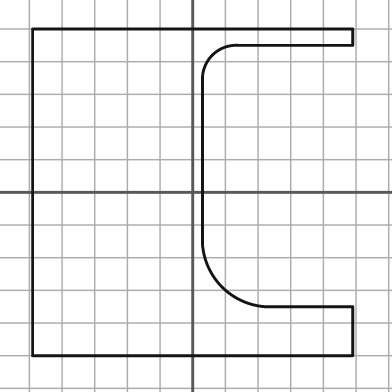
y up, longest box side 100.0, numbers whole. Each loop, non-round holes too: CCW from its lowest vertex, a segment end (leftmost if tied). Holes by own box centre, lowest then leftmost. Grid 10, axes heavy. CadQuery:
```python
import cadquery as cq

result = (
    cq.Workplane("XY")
    .moveTo(-49.0, -50.0)
    .lineTo(49.0, -50.0)
    .lineTo(49.0, -35.0)
    .lineTo(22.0, -35.0)
    .threePointArc((9.0, -29.0), (3.0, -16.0))
    .lineTo(3.0, 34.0)
    .threePointArc((6.0, 42.0), (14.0, 45.0))
    .lineTo(49.0, 45.0)
    .lineTo(49.0, 50.0)
    .lineTo(-49.0, 50.0)
    .close()
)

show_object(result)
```